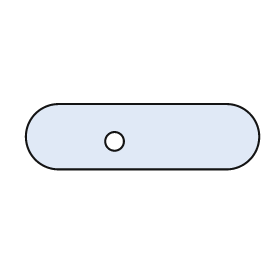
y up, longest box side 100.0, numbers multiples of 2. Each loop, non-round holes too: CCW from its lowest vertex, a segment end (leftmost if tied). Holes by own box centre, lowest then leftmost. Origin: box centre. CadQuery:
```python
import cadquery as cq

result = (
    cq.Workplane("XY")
    .moveTo(-36.0, -14.0)
    .lineTo(36.0, -14.0)
    .threePointArc((50.0, 0.0), (36.0, 14.0))
    .lineTo(-36.0, 14.0)
    .threePointArc((-50.0, 0.0), (-36.0, -14.0))
    .close()
    .moveTo(-12.0, -2.0)
    .circle(4.0)
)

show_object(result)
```